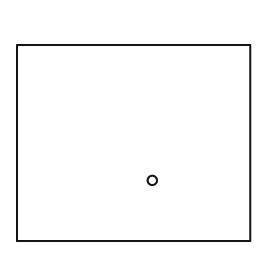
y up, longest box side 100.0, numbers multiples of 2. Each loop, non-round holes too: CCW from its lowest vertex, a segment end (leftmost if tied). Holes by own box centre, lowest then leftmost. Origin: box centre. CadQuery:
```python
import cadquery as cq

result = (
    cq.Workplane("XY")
    .moveTo(-50.0, -42.0)
    .lineTo(50.0, -42.0)
    .lineTo(50.0, 42.0)
    .lineTo(-50.0, 42.0)
    .close()
    .moveTo(8.0, -16.0)
    .circle(2.0)
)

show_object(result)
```